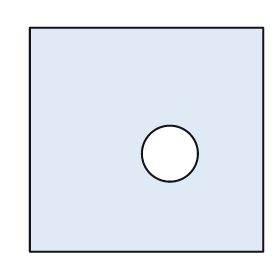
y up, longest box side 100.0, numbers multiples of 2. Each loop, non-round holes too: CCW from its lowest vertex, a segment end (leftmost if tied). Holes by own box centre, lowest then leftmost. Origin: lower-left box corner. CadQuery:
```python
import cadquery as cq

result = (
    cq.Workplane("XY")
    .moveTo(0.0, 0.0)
    .lineTo(100.0, 0.0)
    .lineTo(100.0, 96.0)
    .lineTo(0.0, 96.0)
    .close()
    .moveTo(60.0, 42.0)
    .circle(12.0)
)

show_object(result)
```